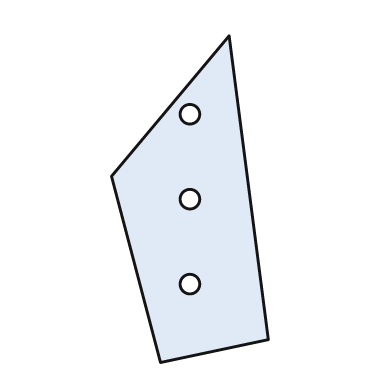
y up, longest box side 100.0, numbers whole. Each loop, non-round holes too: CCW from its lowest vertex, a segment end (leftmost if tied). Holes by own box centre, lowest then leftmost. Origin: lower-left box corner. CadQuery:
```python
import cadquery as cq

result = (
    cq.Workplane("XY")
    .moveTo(15.0, 0.0)
    .lineTo(48.0, 7.0)
    .lineTo(36.0, 100.0)
    .lineTo(0.0, 57.0)
    .close()
    .moveTo(24.0, 24.0)
    .circle(3.0)
    .moveTo(24.0, 50.0)
    .circle(3.0)
    .moveTo(24.0, 76.0)
    .circle(3.0)
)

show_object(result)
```